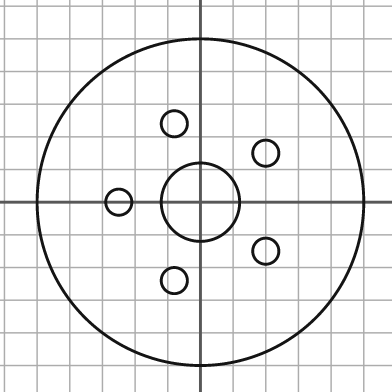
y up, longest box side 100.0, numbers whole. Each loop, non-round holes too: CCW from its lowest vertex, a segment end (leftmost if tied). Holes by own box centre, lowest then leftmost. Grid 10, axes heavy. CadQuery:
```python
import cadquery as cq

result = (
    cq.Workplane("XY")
    .moveTo(0.0, 0.0)
    .circle(50.0)
    .moveTo(-8.0, -24.0)
    .circle(4.0)
    .moveTo(20.0, -15.0)
    .circle(4.0)
    .moveTo(-25.0, 0.0)
    .circle(4.0)
    .moveTo(0.0, 0.0)
    .circle(12.0)
    .moveTo(20.0, 15.0)
    .circle(4.0)
    .moveTo(-8.0, 24.0)
    .circle(4.0)
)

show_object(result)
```